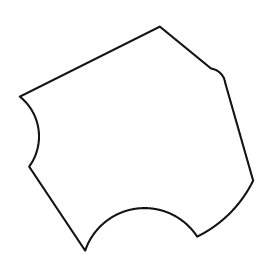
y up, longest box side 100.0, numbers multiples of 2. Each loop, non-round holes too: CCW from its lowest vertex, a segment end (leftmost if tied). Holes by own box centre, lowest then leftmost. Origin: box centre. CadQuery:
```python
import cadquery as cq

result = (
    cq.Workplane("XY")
    .moveTo(-22.0, -48.0)
    .threePointArc((0.0, -30.0), (26.0, -42.0))
    .threePointArc((40.0, -32.0), (50.0, -18.0))
    .lineTo(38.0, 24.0)
    .threePointArc((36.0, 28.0), (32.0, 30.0))
    .lineTo(10.0, 48.0)
    .lineTo(-50.0, 18.0)
    .threePointArc((-42.0, 4.0), (-46.0, -12.0))
    .close()
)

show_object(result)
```